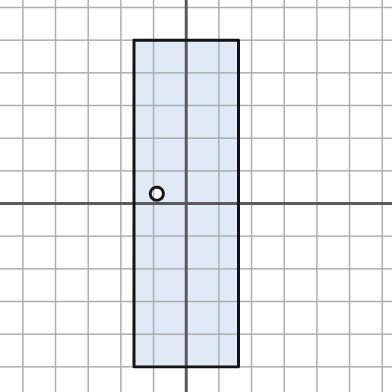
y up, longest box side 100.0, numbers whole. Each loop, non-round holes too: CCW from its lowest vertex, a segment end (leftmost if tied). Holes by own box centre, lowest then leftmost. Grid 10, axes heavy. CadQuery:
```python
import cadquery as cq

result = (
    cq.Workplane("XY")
    .moveTo(-16.0, -50.0)
    .lineTo(16.0, -50.0)
    .lineTo(16.0, 50.0)
    .lineTo(-16.0, 50.0)
    .close()
    .moveTo(-9.0, 3.0)
    .circle(2.0)
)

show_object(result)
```